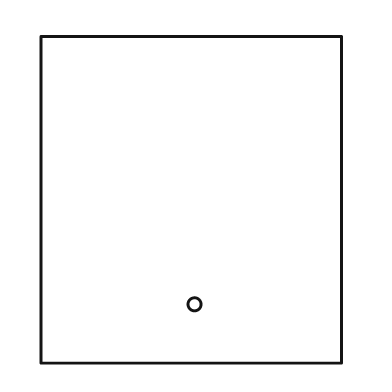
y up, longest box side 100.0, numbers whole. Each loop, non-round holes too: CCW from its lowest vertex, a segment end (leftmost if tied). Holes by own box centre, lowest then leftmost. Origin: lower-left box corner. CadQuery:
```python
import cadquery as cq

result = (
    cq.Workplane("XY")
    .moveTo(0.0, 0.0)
    .lineTo(92.0, 0.0)
    .lineTo(92.0, 100.0)
    .lineTo(0.0, 100.0)
    .close()
    .moveTo(47.0, 18.0)
    .circle(2.0)
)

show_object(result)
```